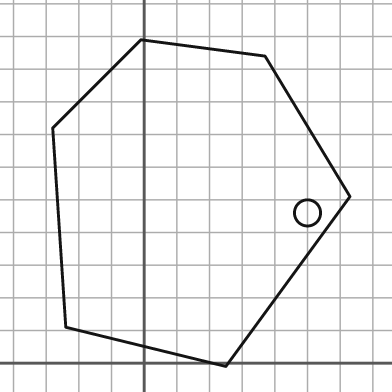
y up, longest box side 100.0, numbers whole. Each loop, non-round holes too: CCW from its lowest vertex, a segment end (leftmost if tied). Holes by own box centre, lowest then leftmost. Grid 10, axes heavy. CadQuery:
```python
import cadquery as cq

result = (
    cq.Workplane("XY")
    .moveTo(25.0, -1.0)
    .lineTo(63.0, 51.0)
    .lineTo(37.0, 94.0)
    .lineTo(-1.0, 99.0)
    .lineTo(-28.0, 72.0)
    .lineTo(-24.0, 11.0)
    .close()
    .moveTo(50.0, 46.0)
    .circle(4.0)
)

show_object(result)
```